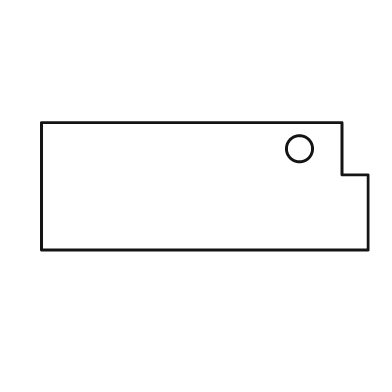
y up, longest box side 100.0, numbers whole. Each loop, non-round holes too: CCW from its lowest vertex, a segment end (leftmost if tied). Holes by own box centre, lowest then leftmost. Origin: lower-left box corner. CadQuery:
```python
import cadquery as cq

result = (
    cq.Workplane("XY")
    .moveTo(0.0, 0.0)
    .lineTo(100.0, 0.0)
    .lineTo(100.0, 23.0)
    .lineTo(92.0, 23.0)
    .lineTo(92.0, 39.0)
    .lineTo(0.0, 39.0)
    .close()
    .moveTo(79.0, 31.0)
    .circle(4.0)
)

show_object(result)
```